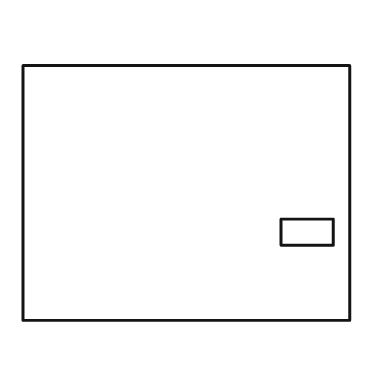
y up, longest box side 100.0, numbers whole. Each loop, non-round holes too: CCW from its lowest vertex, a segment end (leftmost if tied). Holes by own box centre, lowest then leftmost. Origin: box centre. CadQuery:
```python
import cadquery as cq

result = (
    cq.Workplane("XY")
    .moveTo(-50.0, -39.0)
    .lineTo(50.0, -39.0)
    .lineTo(50.0, 39.0)
    .lineTo(-50.0, 39.0)
    .close()
    .moveTo(29.0, -16.0)
    .lineTo(45.0, -16.0)
    .lineTo(45.0, -8.0)
    .lineTo(29.0, -8.0)
    .close()
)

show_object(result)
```